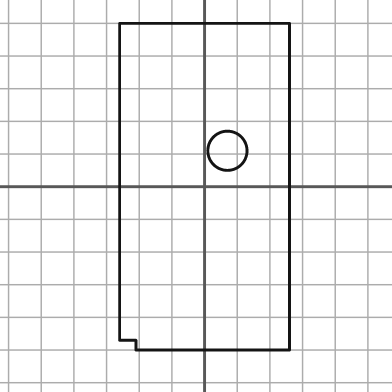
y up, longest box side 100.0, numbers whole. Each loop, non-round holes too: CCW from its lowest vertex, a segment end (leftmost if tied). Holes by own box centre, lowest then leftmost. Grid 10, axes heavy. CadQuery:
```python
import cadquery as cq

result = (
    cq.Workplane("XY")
    .moveTo(-21.0, -50.0)
    .lineTo(26.0, -50.0)
    .lineTo(26.0, 50.0)
    .lineTo(-26.0, 50.0)
    .lineTo(-26.0, -47.0)
    .lineTo(-21.0, -47.0)
    .close()
    .moveTo(7.0, 11.0)
    .circle(6.0)
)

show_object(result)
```